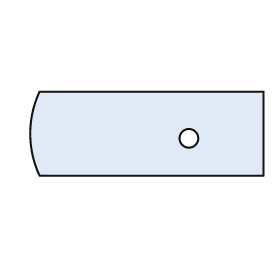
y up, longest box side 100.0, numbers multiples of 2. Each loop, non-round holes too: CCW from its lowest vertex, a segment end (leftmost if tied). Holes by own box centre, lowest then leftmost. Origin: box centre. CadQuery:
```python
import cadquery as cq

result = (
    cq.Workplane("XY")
    .moveTo(-46.0, -18.0)
    .lineTo(50.0, -18.0)
    .lineTo(50.0, 18.0)
    .lineTo(-46.0, 18.0)
    .threePointArc((-50.0, 0.0), (-46.0, -18.0))
    .close()
    .moveTo(18.0, -2.0)
    .circle(4.0)
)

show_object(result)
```